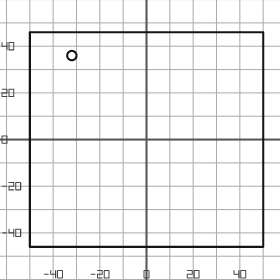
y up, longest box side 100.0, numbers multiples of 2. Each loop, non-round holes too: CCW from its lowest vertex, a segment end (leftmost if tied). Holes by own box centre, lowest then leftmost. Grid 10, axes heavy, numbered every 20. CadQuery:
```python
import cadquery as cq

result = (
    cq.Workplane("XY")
    .moveTo(-50.0, -46.0)
    .lineTo(50.0, -46.0)
    .lineTo(50.0, 46.0)
    .lineTo(-50.0, 46.0)
    .close()
    .moveTo(-32.0, 36.0)
    .circle(2.0)
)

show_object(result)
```